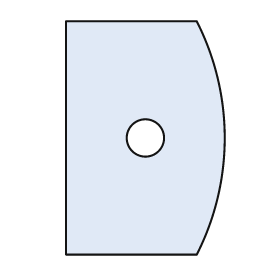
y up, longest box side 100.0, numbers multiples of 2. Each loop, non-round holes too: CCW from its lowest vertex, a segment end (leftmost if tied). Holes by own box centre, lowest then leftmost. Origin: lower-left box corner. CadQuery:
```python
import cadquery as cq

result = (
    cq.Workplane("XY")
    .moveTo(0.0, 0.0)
    .lineTo(56.0, 0.0)
    .threePointArc((68.0, 50.0), (56.0, 100.0))
    .lineTo(0.0, 100.0)
    .close()
    .moveTo(34.0, 50.0)
    .circle(8.0)
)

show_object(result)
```